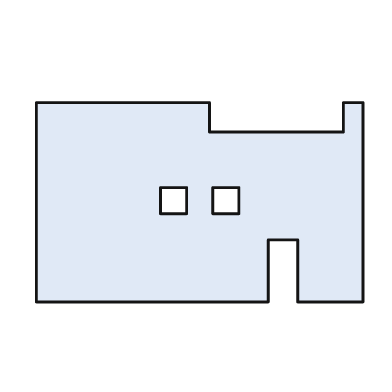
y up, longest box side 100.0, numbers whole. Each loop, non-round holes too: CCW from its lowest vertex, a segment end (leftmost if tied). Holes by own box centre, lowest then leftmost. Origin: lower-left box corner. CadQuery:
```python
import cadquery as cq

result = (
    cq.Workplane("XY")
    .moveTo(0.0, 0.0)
    .lineTo(71.0, 0.0)
    .lineTo(71.0, 19.0)
    .lineTo(80.0, 19.0)
    .lineTo(80.0, 0.0)
    .lineTo(100.0, 0.0)
    .lineTo(100.0, 61.0)
    .lineTo(94.0, 61.0)
    .lineTo(94.0, 52.0)
    .lineTo(53.0, 52.0)
    .lineTo(53.0, 61.0)
    .lineTo(0.0, 61.0)
    .close()
    .moveTo(38.0, 27.0)
    .lineTo(46.0, 27.0)
    .lineTo(46.0, 35.0)
    .lineTo(38.0, 35.0)
    .close()
    .moveTo(54.0, 27.0)
    .lineTo(62.0, 27.0)
    .lineTo(62.0, 35.0)
    .lineTo(54.0, 35.0)
    .close()
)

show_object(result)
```